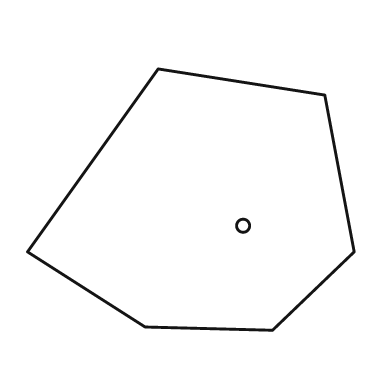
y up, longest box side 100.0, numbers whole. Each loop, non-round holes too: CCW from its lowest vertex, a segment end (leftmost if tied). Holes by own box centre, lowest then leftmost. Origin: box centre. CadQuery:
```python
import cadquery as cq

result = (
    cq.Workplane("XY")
    .moveTo(25.0, -40.0)
    .lineTo(50.0, -16.0)
    .lineTo(41.0, 32.0)
    .lineTo(-10.0, 40.0)
    .lineTo(-50.0, -16.0)
    .lineTo(-14.0, -39.0)
    .close()
    .moveTo(16.0, -8.0)
    .circle(2.0)
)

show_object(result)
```